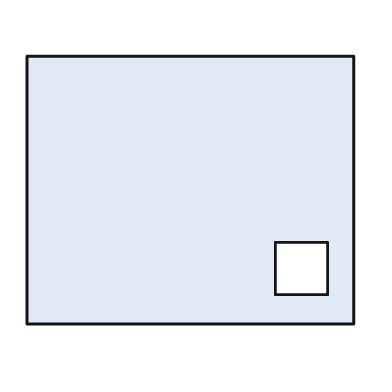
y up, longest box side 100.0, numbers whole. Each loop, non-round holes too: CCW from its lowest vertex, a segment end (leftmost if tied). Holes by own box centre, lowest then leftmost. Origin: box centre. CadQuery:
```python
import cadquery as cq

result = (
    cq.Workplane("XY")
    .moveTo(-50.0, -41.0)
    .lineTo(50.0, -41.0)
    .lineTo(50.0, 41.0)
    .lineTo(-50.0, 41.0)
    .close()
    .moveTo(26.0, -32.0)
    .lineTo(42.0, -32.0)
    .lineTo(42.0, -16.0)
    .lineTo(26.0, -16.0)
    .close()
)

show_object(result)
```